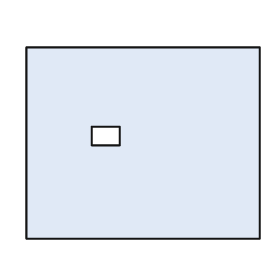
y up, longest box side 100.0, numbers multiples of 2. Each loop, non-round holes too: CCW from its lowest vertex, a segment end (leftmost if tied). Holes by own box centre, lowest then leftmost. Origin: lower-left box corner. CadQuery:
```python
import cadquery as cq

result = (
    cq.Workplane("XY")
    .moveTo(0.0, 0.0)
    .lineTo(100.0, 0.0)
    .lineTo(100.0, 82.0)
    .lineTo(0.0, 82.0)
    .close()
    .moveTo(28.0, 40.0)
    .lineTo(40.0, 40.0)
    .lineTo(40.0, 48.0)
    .lineTo(28.0, 48.0)
    .close()
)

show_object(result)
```